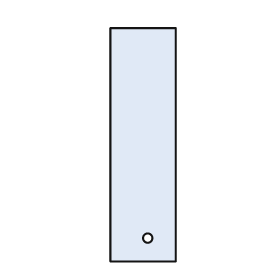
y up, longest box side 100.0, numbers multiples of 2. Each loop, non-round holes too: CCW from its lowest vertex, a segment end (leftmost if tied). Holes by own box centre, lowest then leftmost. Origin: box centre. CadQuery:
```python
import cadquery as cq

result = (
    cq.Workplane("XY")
    .moveTo(-14.0, -50.0)
    .lineTo(14.0, -50.0)
    .lineTo(14.0, 50.0)
    .lineTo(-14.0, 50.0)
    .close()
    .moveTo(2.0, -40.0)
    .circle(2.0)
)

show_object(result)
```